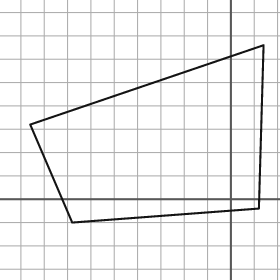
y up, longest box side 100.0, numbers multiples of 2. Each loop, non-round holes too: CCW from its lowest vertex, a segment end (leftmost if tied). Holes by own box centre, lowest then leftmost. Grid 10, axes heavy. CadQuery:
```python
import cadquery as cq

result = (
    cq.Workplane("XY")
    .moveTo(-68.0, -10.0)
    .lineTo(12.0, -4.0)
    .lineTo(14.0, 66.0)
    .lineTo(-86.0, 32.0)
    .close()
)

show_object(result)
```